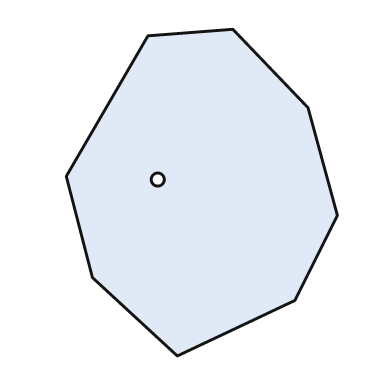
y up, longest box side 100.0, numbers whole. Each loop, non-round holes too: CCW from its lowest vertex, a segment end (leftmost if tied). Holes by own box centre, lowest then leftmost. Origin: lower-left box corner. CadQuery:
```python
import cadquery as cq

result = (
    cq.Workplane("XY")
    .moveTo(34.0, 0.0)
    .lineTo(70.0, 17.0)
    .lineTo(83.0, 43.0)
    .lineTo(74.0, 76.0)
    .lineTo(51.0, 100.0)
    .lineTo(25.0, 98.0)
    .lineTo(0.0, 55.0)
    .lineTo(8.0, 24.0)
    .close()
    .moveTo(28.0, 54.0)
    .circle(2.0)
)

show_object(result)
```